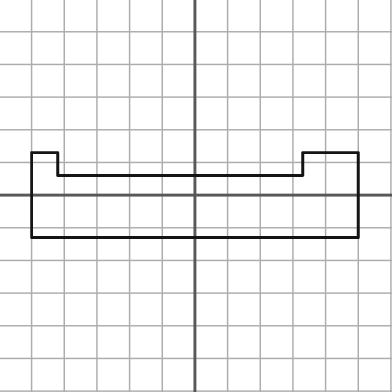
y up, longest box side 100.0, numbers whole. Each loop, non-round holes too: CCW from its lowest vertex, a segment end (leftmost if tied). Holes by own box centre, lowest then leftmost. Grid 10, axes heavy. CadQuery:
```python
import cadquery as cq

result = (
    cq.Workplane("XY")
    .moveTo(-50.0, -13.0)
    .lineTo(50.0, -13.0)
    .lineTo(50.0, 13.0)
    .lineTo(33.0, 13.0)
    .lineTo(33.0, 6.0)
    .lineTo(-42.0, 6.0)
    .lineTo(-42.0, 13.0)
    .lineTo(-50.0, 13.0)
    .close()
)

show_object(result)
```